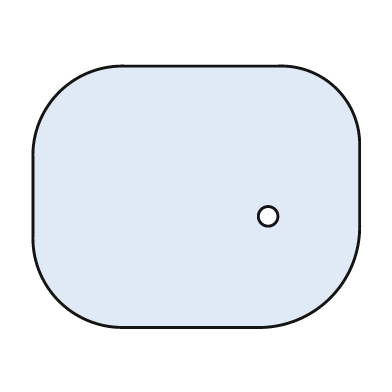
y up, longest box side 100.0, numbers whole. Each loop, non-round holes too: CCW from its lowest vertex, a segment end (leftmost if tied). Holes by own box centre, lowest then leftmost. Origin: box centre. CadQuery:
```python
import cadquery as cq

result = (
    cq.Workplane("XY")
    .moveTo(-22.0, -40.0)
    .lineTo(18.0, -40.0)
    .threePointArc((41.0, -31.0), (50.0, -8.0))
    .lineTo(50.0, 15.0)
    .threePointArc((43.0, 33.0), (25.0, 40.0))
    .lineTo(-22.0, 40.0)
    .threePointArc((-42.0, 32.0), (-50.0, 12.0))
    .lineTo(-50.0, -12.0)
    .threePointArc((-42.0, -32.0), (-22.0, -40.0))
    .close()
    .moveTo(22.0, -6.0)
    .circle(3.0)
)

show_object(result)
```